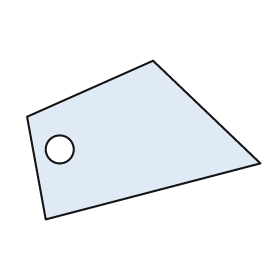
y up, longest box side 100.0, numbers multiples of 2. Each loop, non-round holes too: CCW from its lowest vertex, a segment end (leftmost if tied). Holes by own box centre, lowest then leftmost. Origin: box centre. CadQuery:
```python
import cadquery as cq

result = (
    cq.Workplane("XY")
    .moveTo(-42.0, -34.0)
    .lineTo(50.0, -10.0)
    .lineTo(4.0, 34.0)
    .lineTo(-50.0, 10.0)
    .close()
    .moveTo(-36.0, -4.0)
    .circle(6.0)
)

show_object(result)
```